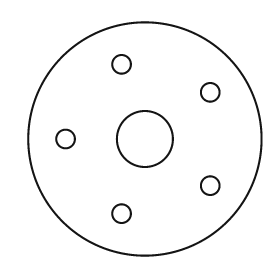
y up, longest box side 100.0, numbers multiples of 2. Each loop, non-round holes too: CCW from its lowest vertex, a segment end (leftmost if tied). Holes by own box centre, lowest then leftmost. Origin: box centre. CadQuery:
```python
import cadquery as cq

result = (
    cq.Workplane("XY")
    .moveTo(0.0, 0.0)
    .circle(50.0)
    .moveTo(-10.0, -32.0)
    .circle(4.0)
    .moveTo(28.0, -20.0)
    .circle(4.0)
    .moveTo(-34.0, 0.0)
    .circle(4.0)
    .moveTo(0.0, 0.0)
    .circle(12.0)
    .moveTo(28.0, 20.0)
    .circle(4.0)
    .moveTo(-10.0, 32.0)
    .circle(4.0)
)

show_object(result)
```